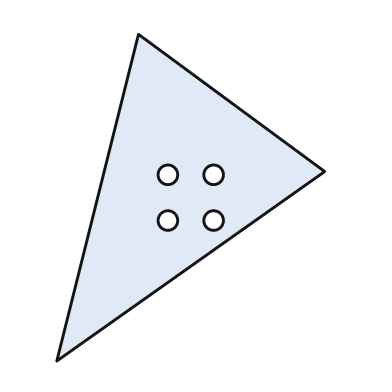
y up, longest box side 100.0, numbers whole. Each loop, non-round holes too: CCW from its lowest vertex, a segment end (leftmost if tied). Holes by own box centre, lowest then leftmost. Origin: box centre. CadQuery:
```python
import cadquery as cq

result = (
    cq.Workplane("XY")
    .moveTo(-41.0, -50.0)
    .lineTo(41.0, 8.0)
    .lineTo(-16.0, 50.0)
    .close()
    .moveTo(-7.0, -7.0)
    .circle(3.0)
    .moveTo(7.0, -7.0)
    .circle(3.0)
    .moveTo(-7.0, 7.0)
    .circle(3.0)
    .moveTo(7.0, 7.0)
    .circle(3.0)
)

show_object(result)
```